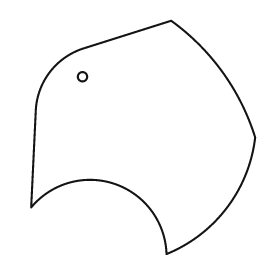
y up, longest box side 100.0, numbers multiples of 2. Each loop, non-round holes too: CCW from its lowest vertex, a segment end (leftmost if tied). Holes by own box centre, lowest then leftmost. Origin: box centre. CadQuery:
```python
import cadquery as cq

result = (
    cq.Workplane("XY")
    .moveTo(10.0, -50.0)
    .threePointArc((36.0, -30.0), (48.0, 0.0))
    .threePointArc((34.0, 28.0), (12.0, 50.0))
    .lineTo(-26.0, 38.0)
    .threePointArc((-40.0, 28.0), (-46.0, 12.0))
    .lineTo(-48.0, -30.0)
    .threePointArc((-12.0, -20.0), (10.0, -50.0))
    .close()
    .moveTo(-26.0, 26.0)
    .circle(2.0)
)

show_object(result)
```